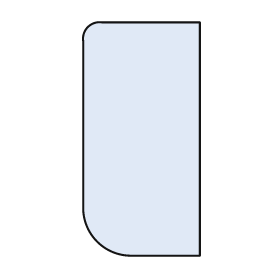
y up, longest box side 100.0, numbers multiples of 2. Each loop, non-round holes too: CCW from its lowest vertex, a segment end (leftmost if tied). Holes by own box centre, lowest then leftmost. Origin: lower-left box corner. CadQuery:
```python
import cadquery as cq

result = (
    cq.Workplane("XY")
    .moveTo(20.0, 0.0)
    .lineTo(50.0, 0.0)
    .lineTo(50.0, 100.0)
    .lineTo(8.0, 100.0)
    .threePointArc((2.0, 98.0), (0.0, 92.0))
    .lineTo(0.0, 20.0)
    .threePointArc((6.0, 6.0), (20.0, 0.0))
    .close()
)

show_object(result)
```